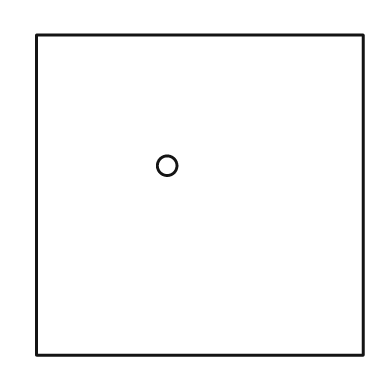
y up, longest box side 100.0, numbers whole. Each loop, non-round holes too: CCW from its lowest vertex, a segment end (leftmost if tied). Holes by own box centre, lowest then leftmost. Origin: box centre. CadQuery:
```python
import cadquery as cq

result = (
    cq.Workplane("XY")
    .moveTo(-50.0, -49.0)
    .lineTo(50.0, -49.0)
    .lineTo(50.0, 49.0)
    .lineTo(-50.0, 49.0)
    .close()
    .moveTo(-10.0, 9.0)
    .circle(3.0)
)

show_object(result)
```